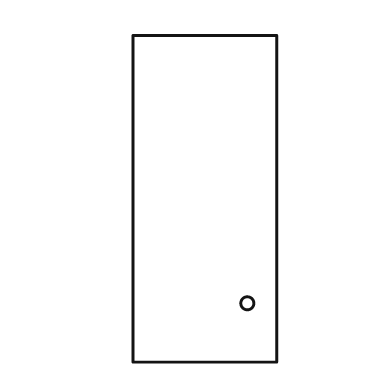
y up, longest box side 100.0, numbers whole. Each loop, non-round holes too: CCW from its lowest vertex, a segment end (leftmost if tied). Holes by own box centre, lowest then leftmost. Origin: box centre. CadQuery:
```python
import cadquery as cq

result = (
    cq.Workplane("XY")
    .moveTo(-22.0, -50.0)
    .lineTo(22.0, -50.0)
    .lineTo(22.0, 50.0)
    .lineTo(-22.0, 50.0)
    .close()
    .moveTo(13.0, -32.0)
    .circle(2.0)
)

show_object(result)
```